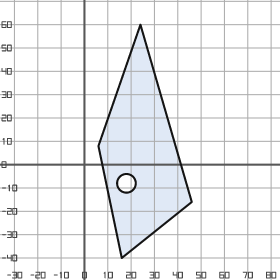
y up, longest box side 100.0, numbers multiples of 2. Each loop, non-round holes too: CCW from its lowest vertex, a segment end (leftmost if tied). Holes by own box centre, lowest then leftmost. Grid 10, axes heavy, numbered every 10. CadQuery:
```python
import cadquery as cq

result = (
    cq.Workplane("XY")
    .moveTo(16.0, -40.0)
    .lineTo(46.0, -16.0)
    .lineTo(24.0, 60.0)
    .lineTo(6.0, 8.0)
    .close()
    .moveTo(18.0, -8.0)
    .circle(4.0)
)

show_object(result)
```